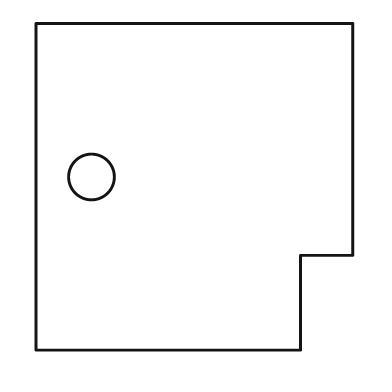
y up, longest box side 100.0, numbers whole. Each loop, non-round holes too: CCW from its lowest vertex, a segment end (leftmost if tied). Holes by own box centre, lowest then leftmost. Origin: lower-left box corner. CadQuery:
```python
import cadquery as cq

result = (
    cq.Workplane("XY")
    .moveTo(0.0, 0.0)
    .lineTo(81.0, 0.0)
    .lineTo(81.0, 29.0)
    .lineTo(97.0, 29.0)
    .lineTo(97.0, 100.0)
    .lineTo(0.0, 100.0)
    .close()
    .moveTo(17.0, 53.0)
    .circle(7.0)
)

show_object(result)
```